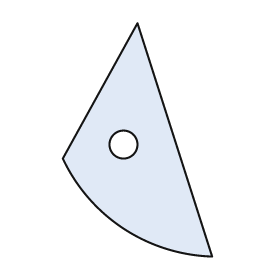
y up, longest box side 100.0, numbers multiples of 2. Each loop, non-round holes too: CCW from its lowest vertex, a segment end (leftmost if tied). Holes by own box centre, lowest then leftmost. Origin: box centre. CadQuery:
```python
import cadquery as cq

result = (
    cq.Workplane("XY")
    .moveTo(32.0, -50.0)
    .lineTo(0.0, 50.0)
    .lineTo(-32.0, -8.0)
    .threePointArc((-6.0, -38.0), (32.0, -50.0))
    .close()
    .moveTo(-6.0, -2.0)
    .circle(6.0)
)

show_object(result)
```